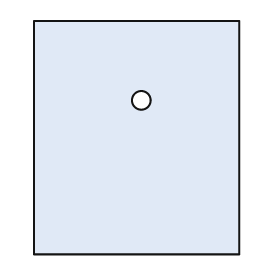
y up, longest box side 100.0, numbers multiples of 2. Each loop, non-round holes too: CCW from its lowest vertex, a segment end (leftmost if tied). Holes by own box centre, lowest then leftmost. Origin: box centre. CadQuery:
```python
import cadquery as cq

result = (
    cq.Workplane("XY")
    .moveTo(-44.0, -50.0)
    .lineTo(44.0, -50.0)
    .lineTo(44.0, 50.0)
    .lineTo(-44.0, 50.0)
    .close()
    .moveTo(2.0, 16.0)
    .circle(4.0)
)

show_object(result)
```